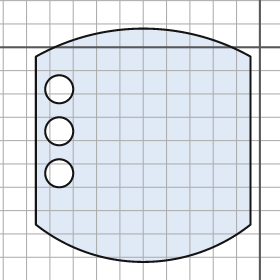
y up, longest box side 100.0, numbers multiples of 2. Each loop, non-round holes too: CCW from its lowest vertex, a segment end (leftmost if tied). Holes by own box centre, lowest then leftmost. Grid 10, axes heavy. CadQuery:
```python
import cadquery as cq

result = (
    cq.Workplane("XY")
    .moveTo(-96.0, -76.0)
    .threePointArc((-50.0, -92.0), (-4.0, -76.0))
    .lineTo(-4.0, -4.0)
    .threePointArc((-50.0, 8.0), (-96.0, -4.0))
    .close()
    .moveTo(-86.0, -54.0)
    .circle(6.0)
    .moveTo(-86.0, -36.0)
    .circle(6.0)
    .moveTo(-86.0, -18.0)
    .circle(6.0)
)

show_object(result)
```